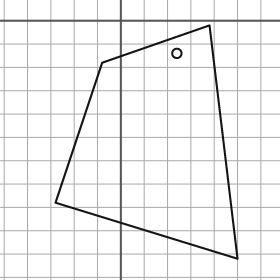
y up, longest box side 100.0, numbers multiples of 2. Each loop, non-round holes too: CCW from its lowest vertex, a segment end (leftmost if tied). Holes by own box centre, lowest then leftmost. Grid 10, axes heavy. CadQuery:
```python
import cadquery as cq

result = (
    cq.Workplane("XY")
    .moveTo(50.0, -102.0)
    .lineTo(38.0, -2.0)
    .lineTo(-8.0, -18.0)
    .lineTo(-28.0, -78.0)
    .close()
    .moveTo(24.0, -14.0)
    .circle(2.0)
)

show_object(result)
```